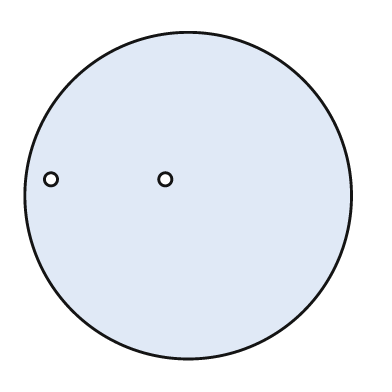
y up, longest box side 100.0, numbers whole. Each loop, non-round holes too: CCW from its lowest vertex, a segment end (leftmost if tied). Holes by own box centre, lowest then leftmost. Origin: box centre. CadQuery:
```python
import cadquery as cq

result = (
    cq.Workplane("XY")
    .moveTo(0.0, 0.0)
    .circle(50.0)
    .moveTo(-42.0, 5.0)
    .circle(2.0)
    .moveTo(-7.0, 5.0)
    .circle(2.0)
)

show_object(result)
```